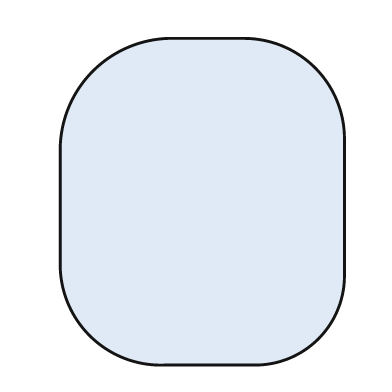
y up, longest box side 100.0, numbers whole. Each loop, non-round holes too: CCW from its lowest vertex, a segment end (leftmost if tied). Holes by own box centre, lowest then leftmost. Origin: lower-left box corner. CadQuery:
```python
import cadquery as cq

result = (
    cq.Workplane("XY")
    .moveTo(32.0, 0.0)
    .lineTo(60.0, 0.0)
    .threePointArc((79.0, 8.0), (87.0, 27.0))
    .lineTo(87.0, 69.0)
    .threePointArc((78.0, 91.0), (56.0, 100.0))
    .lineTo(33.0, 100.0)
    .threePointArc((10.0, 90.0), (0.0, 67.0))
    .lineTo(0.0, 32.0)
    .threePointArc((9.0, 9.0), (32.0, 0.0))
    .close()
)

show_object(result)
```